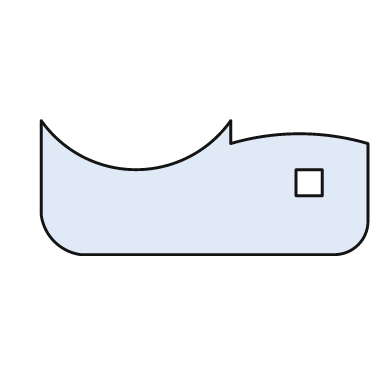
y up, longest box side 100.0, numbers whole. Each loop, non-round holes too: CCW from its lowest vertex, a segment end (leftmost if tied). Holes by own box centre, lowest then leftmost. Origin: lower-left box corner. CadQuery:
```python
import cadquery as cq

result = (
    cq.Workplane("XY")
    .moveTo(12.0, 0.0)
    .lineTo(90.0, 0.0)
    .threePointArc((97.0, 3.0), (100.0, 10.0))
    .lineTo(100.0, 34.0)
    .threePointArc((79.0, 37.0), (58.0, 34.0))
    .lineTo(58.0, 41.0)
    .threePointArc((29.0, 26.0), (0.0, 41.0))
    .lineTo(0.0, 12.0)
    .threePointArc((4.0, 4.0), (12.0, 0.0))
    .close()
    .moveTo(78.0, 18.0)
    .lineTo(86.0, 18.0)
    .lineTo(86.0, 26.0)
    .lineTo(78.0, 26.0)
    .close()
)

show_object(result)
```